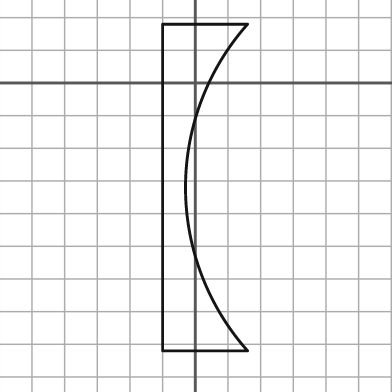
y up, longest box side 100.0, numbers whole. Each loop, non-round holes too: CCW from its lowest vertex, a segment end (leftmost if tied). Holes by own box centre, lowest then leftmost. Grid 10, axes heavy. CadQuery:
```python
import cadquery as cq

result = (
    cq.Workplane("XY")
    .moveTo(-10.0, -82.0)
    .lineTo(16.0, -82.0)
    .threePointArc((-3.0, -32.0), (16.0, 18.0))
    .lineTo(-10.0, 18.0)
    .close()
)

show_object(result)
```